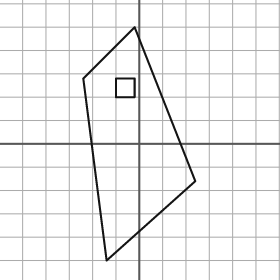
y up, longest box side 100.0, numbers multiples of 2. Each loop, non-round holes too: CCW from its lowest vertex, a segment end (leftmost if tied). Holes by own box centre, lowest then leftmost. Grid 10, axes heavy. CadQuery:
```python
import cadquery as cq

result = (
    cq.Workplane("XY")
    .moveTo(-14.0, -50.0)
    .lineTo(24.0, -16.0)
    .lineTo(-2.0, 50.0)
    .lineTo(-24.0, 28.0)
    .close()
    .moveTo(-10.0, 20.0)
    .lineTo(-2.0, 20.0)
    .lineTo(-2.0, 28.0)
    .lineTo(-10.0, 28.0)
    .close()
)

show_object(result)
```